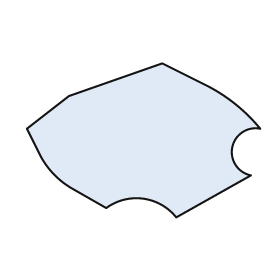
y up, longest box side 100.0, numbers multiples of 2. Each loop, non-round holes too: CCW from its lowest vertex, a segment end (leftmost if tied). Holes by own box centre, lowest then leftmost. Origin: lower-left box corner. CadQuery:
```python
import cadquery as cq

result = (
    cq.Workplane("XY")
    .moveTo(64.0, 0.0)
    .lineTo(96.0, 18.0)
    .threePointArc((88.0, 30.0), (100.0, 38.0))
    .threePointArc((90.0, 48.0), (78.0, 56.0))
    .lineTo(58.0, 66.0)
    .lineTo(18.0, 52.0)
    .lineTo(0.0, 38.0)
    .lineTo(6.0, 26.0)
    .threePointArc((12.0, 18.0), (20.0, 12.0))
    .lineTo(34.0, 4.0)
    .threePointArc((50.0, 8.0), (64.0, 0.0))
    .close()
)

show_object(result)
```